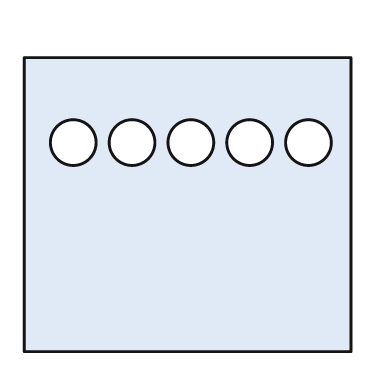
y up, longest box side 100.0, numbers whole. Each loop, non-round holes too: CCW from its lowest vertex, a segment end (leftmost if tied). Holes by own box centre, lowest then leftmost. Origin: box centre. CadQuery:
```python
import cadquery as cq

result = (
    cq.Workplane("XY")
    .moveTo(-50.0, -45.0)
    .lineTo(50.0, -45.0)
    .lineTo(50.0, 45.0)
    .lineTo(-50.0, 45.0)
    .close()
    .moveTo(-35.0, 19.0)
    .circle(7.0)
    .moveTo(-17.0, 19.0)
    .circle(7.0)
    .moveTo(1.0, 19.0)
    .circle(7.0)
    .moveTo(19.0, 19.0)
    .circle(7.0)
    .moveTo(37.0, 19.0)
    .circle(7.0)
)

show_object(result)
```